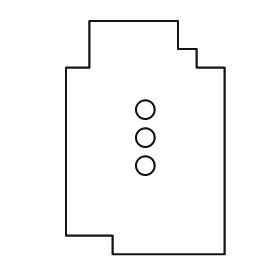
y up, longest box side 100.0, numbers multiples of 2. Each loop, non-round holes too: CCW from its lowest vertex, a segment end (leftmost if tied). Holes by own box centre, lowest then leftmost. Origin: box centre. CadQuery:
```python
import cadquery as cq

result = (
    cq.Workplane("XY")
    .moveTo(-14.0, -50.0)
    .lineTo(34.0, -50.0)
    .lineTo(34.0, 30.0)
    .lineTo(22.0, 30.0)
    .lineTo(22.0, 38.0)
    .lineTo(14.0, 38.0)
    .lineTo(14.0, 50.0)
    .lineTo(-24.0, 50.0)
    .lineTo(-24.0, 30.0)
    .lineTo(-34.0, 30.0)
    .lineTo(-34.0, -42.0)
    .lineTo(-14.0, -42.0)
    .close()
    .moveTo(0.0, -12.0)
    .circle(4.0)
    .moveTo(0.0, 0.0)
    .circle(4.0)
    .moveTo(0.0, 12.0)
    .circle(4.0)
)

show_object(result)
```